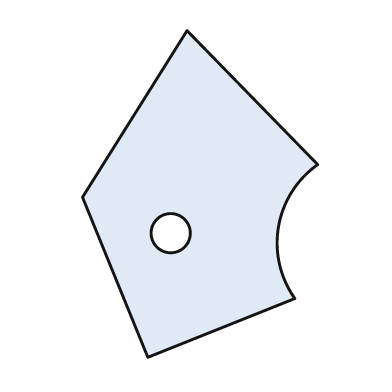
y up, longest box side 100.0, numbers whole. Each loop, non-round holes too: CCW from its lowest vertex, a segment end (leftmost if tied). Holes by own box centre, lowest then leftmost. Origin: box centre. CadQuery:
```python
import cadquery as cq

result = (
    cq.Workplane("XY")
    .moveTo(-16.0, -50.0)
    .lineTo(29.0, -32.0)
    .threePointArc((24.0, -10.0), (36.0, 9.0))
    .lineTo(-4.0, 50.0)
    .lineTo(-36.0, -1.0)
    .close()
    .moveTo(-9.0, -12.0)
    .circle(6.0)
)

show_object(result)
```